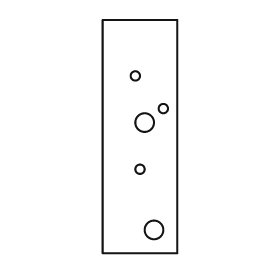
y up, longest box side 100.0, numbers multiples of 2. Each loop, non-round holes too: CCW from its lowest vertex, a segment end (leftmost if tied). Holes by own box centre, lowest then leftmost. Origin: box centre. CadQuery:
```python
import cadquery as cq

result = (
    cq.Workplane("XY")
    .moveTo(-16.0, -50.0)
    .lineTo(16.0, -50.0)
    .lineTo(16.0, 50.0)
    .lineTo(-16.0, 50.0)
    .close()
    .moveTo(6.0, -40.0)
    .circle(4.0)
    .moveTo(0.0, -14.0)
    .circle(2.0)
    .moveTo(2.0, 6.0)
    .circle(4.0)
    .moveTo(10.0, 12.0)
    .circle(2.0)
    .moveTo(-2.0, 26.0)
    .circle(2.0)
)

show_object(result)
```